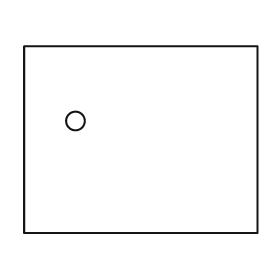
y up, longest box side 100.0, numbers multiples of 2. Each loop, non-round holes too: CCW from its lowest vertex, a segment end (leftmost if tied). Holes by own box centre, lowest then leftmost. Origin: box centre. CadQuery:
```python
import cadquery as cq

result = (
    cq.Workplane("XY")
    .moveTo(-50.0, -40.0)
    .lineTo(50.0, -40.0)
    .lineTo(50.0, 40.0)
    .lineTo(-50.0, 40.0)
    .close()
    .moveTo(-28.0, 8.0)
    .circle(4.0)
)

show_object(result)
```